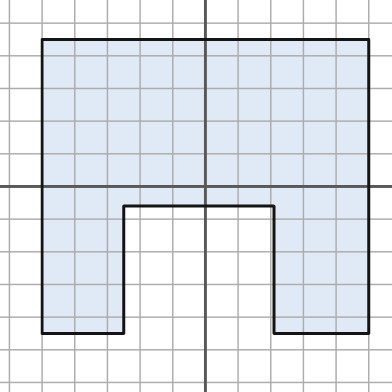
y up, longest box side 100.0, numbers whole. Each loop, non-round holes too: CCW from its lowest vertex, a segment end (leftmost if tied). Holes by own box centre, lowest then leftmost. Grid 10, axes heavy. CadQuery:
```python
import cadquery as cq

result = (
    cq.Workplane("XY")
    .moveTo(-50.0, -45.0)
    .lineTo(-25.0, -45.0)
    .lineTo(-25.0, -6.0)
    .lineTo(21.0, -6.0)
    .lineTo(21.0, -45.0)
    .lineTo(50.0, -45.0)
    .lineTo(50.0, 45.0)
    .lineTo(-50.0, 45.0)
    .close()
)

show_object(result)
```